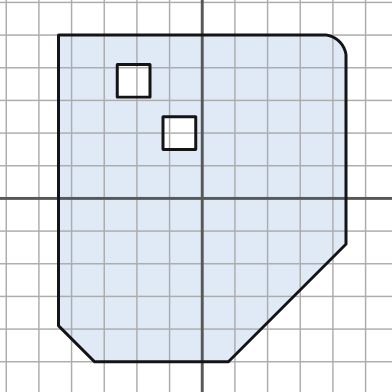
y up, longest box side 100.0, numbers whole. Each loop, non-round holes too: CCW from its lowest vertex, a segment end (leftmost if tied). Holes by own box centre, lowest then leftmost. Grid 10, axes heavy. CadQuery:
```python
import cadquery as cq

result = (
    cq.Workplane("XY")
    .moveTo(-33.0, -50.0)
    .lineTo(8.0, -50.0)
    .lineTo(44.0, -14.0)
    .lineTo(44.0, 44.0)
    .threePointArc((42.0, 48.0), (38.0, 50.0))
    .lineTo(-44.0, 50.0)
    .lineTo(-44.0, -39.0)
    .close()
    .moveTo(-12.0, 15.0)
    .lineTo(-2.0, 15.0)
    .lineTo(-2.0, 25.0)
    .lineTo(-12.0, 25.0)
    .close()
    .moveTo(-26.0, 31.0)
    .lineTo(-16.0, 31.0)
    .lineTo(-16.0, 41.0)
    .lineTo(-26.0, 41.0)
    .close()
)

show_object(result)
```